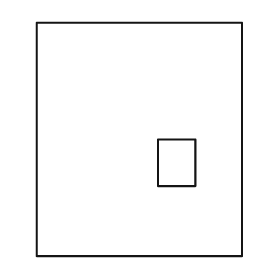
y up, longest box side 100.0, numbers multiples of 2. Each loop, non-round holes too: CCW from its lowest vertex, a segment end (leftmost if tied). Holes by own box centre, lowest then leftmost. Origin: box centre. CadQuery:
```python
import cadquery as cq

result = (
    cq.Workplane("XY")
    .moveTo(-44.0, -50.0)
    .lineTo(44.0, -50.0)
    .lineTo(44.0, 50.0)
    .lineTo(-44.0, 50.0)
    .close()
    .moveTo(8.0, -20.0)
    .lineTo(24.0, -20.0)
    .lineTo(24.0, 0.0)
    .lineTo(8.0, 0.0)
    .close()
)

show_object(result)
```